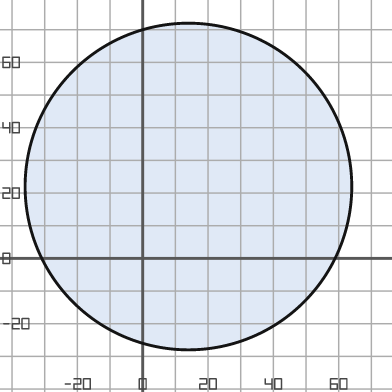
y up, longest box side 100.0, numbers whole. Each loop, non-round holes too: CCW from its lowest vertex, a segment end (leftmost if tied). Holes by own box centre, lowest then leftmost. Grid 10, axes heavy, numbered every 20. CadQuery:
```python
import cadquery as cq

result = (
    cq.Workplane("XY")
    .moveTo(14.0, 22.0)
    .circle(50.0)
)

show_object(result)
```